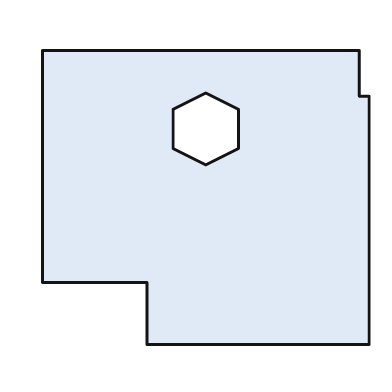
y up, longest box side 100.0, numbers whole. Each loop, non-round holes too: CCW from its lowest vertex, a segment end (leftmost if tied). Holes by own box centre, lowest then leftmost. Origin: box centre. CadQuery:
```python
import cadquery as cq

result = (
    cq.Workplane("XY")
    .moveTo(-18.0, -45.0)
    .lineTo(50.0, -45.0)
    .lineTo(50.0, 31.0)
    .lineTo(47.0, 31.0)
    .lineTo(47.0, 45.0)
    .lineTo(-50.0, 45.0)
    .lineTo(-50.0, -26.0)
    .lineTo(-18.0, -26.0)
    .close()
    .moveTo(0.0, 10.0)
    .lineTo(10.0, 15.0)
    .lineTo(10.0, 27.0)
    .lineTo(0.0, 32.0)
    .lineTo(-10.0, 27.0)
    .lineTo(-10.0, 15.0)
    .close()
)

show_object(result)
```